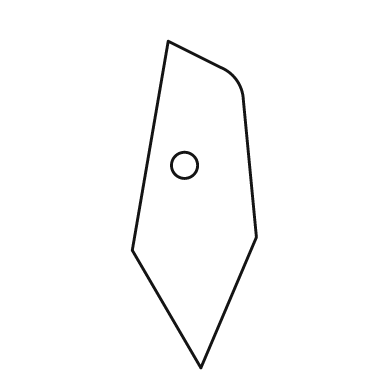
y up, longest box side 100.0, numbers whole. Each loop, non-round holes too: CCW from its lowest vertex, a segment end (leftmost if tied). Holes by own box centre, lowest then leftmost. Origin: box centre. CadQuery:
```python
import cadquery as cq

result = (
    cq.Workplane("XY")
    .moveTo(2.0, -50.0)
    .lineTo(19.0, -10.0)
    .lineTo(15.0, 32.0)
    .threePointArc((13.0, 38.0), (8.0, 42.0))
    .lineTo(-8.0, 50.0)
    .lineTo(-19.0, -14.0)
    .close()
    .moveTo(-3.0, 12.0)
    .circle(4.0)
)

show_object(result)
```